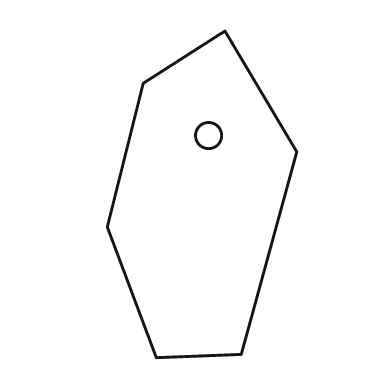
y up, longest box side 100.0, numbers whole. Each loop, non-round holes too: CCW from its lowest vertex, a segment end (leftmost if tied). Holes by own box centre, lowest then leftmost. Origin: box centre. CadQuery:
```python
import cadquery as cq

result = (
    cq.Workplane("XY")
    .moveTo(-14.0, -50.0)
    .lineTo(12.0, -49.0)
    .lineTo(29.0, 13.0)
    .lineTo(7.0, 50.0)
    .lineTo(-18.0, 34.0)
    .lineTo(-29.0, -10.0)
    .close()
    .moveTo(2.0, 18.0)
    .circle(4.0)
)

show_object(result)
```